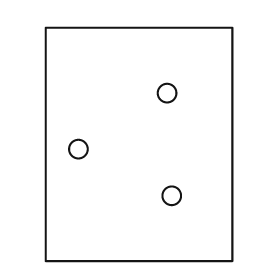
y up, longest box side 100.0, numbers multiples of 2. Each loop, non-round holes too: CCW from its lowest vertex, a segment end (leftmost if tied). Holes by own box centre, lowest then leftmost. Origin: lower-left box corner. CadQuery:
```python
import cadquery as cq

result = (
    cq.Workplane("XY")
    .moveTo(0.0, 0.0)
    .lineTo(80.0, 0.0)
    .lineTo(80.0, 100.0)
    .lineTo(0.0, 100.0)
    .close()
    .moveTo(54.0, 28.0)
    .circle(4.0)
    .moveTo(14.0, 48.0)
    .circle(4.0)
    .moveTo(52.0, 72.0)
    .circle(4.0)
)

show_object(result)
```